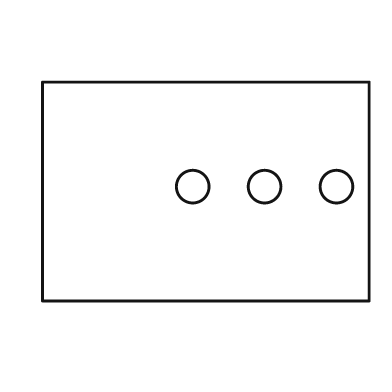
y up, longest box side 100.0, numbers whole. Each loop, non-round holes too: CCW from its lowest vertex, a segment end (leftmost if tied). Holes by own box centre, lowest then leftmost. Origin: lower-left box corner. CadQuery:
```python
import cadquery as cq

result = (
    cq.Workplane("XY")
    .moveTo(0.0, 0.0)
    .lineTo(100.0, 0.0)
    .lineTo(100.0, 67.0)
    .lineTo(0.0, 67.0)
    .close()
    .moveTo(46.0, 35.0)
    .circle(5.0)
    .moveTo(68.0, 35.0)
    .circle(5.0)
    .moveTo(90.0, 35.0)
    .circle(5.0)
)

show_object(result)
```